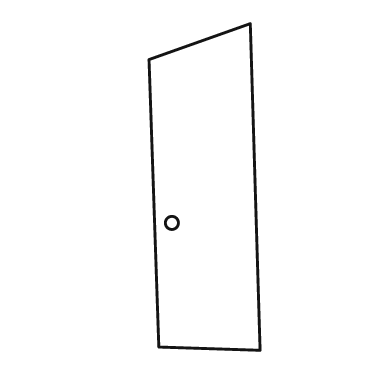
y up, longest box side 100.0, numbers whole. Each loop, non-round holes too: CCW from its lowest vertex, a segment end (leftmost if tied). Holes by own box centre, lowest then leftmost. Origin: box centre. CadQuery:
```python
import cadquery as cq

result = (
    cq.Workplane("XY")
    .moveTo(17.0, -50.0)
    .lineTo(14.0, 50.0)
    .lineTo(-17.0, 39.0)
    .lineTo(-14.0, -49.0)
    .close()
    .moveTo(-10.0, -11.0)
    .circle(2.0)
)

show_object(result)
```